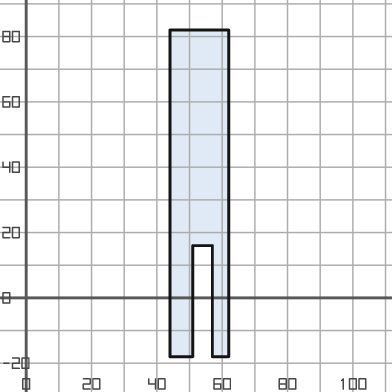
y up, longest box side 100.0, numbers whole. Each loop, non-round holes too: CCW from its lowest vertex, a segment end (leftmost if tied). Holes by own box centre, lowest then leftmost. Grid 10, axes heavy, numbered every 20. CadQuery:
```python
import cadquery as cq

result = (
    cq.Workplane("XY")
    .moveTo(44.0, -18.0)
    .lineTo(51.0, -18.0)
    .lineTo(51.0, 16.0)
    .lineTo(57.0, 16.0)
    .lineTo(57.0, -18.0)
    .lineTo(62.0, -18.0)
    .lineTo(62.0, 82.0)
    .lineTo(44.0, 82.0)
    .close()
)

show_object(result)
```